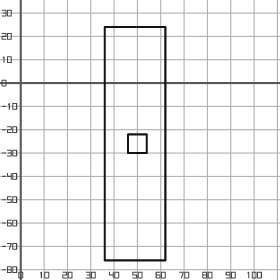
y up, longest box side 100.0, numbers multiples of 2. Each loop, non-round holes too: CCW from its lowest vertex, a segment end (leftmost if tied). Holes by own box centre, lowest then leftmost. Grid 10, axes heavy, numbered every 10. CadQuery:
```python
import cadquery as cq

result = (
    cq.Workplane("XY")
    .moveTo(36.0, -76.0)
    .lineTo(62.0, -76.0)
    .lineTo(62.0, 24.0)
    .lineTo(36.0, 24.0)
    .close()
    .moveTo(46.0, -30.0)
    .lineTo(54.0, -30.0)
    .lineTo(54.0, -22.0)
    .lineTo(46.0, -22.0)
    .close()
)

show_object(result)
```